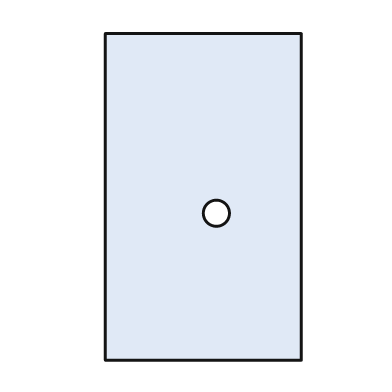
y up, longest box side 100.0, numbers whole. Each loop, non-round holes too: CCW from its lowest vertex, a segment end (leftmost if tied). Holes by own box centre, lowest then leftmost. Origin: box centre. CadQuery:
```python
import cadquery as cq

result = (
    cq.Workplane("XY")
    .moveTo(-30.0, -50.0)
    .lineTo(30.0, -50.0)
    .lineTo(30.0, 50.0)
    .lineTo(-30.0, 50.0)
    .close()
    .moveTo(4.0, -5.0)
    .circle(4.0)
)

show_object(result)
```